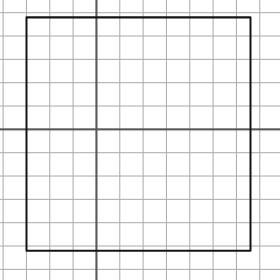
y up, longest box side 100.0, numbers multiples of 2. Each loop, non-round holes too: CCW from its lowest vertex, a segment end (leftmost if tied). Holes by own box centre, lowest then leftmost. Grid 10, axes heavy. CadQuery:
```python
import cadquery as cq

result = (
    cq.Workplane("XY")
    .moveTo(-30.0, -52.0)
    .lineTo(66.0, -52.0)
    .lineTo(66.0, 48.0)
    .lineTo(-30.0, 48.0)
    .close()
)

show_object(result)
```